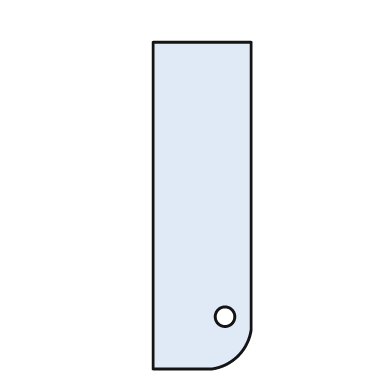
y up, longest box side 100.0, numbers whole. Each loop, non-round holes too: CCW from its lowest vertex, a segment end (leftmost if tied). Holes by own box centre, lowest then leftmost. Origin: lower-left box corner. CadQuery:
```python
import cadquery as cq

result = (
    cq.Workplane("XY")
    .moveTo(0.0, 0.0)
    .lineTo(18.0, 0.0)
    .threePointArc((26.0, 4.0), (30.0, 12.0))
    .lineTo(30.0, 100.0)
    .lineTo(0.0, 100.0)
    .close()
    .moveTo(22.0, 16.0)
    .circle(3.0)
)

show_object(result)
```